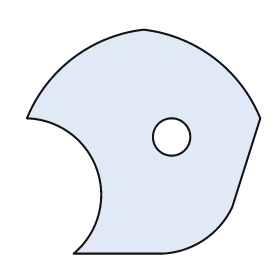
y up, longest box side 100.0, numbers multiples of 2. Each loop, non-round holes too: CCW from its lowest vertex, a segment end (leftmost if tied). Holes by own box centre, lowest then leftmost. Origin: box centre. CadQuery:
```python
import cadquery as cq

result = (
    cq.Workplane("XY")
    .moveTo(-30.0, -48.0)
    .lineTo(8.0, -48.0)
    .threePointArc((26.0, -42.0), (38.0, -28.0))
    .lineTo(50.0, 10.0)
    .threePointArc((30.0, 36.0), (0.0, 48.0))
    .threePointArc((-30.0, 36.0), (-50.0, 10.0))
    .threePointArc((-20.0, -12.0), (-30.0, -48.0))
    .close()
    .moveTo(12.0, 2.0)
    .circle(8.0)
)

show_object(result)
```